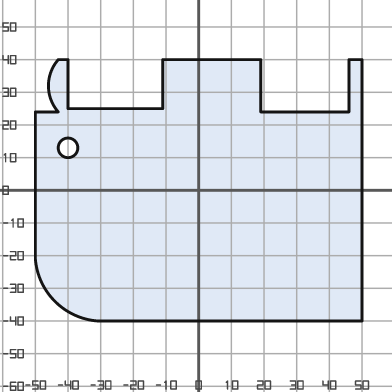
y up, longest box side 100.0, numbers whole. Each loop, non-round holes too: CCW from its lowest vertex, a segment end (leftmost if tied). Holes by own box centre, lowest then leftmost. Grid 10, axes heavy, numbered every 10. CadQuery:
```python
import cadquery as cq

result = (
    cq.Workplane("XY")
    .moveTo(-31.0, -40.0)
    .lineTo(50.0, -40.0)
    .lineTo(50.0, 40.0)
    .lineTo(46.0, 40.0)
    .lineTo(46.0, 24.0)
    .lineTo(19.0, 24.0)
    .lineTo(19.0, 40.0)
    .lineTo(-11.0, 40.0)
    .lineTo(-11.0, 25.0)
    .lineTo(-40.0, 25.0)
    .lineTo(-40.0, 40.0)
    .lineTo(-43.0, 40.0)
    .threePointArc((-46.0, 32.0), (-43.0, 24.0))
    .lineTo(-50.0, 24.0)
    .lineTo(-50.0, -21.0)
    .threePointArc((-44.0, -34.0), (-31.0, -40.0))
    .close()
    .moveTo(-40.0, 13.0)
    .circle(3.0)
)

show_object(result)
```